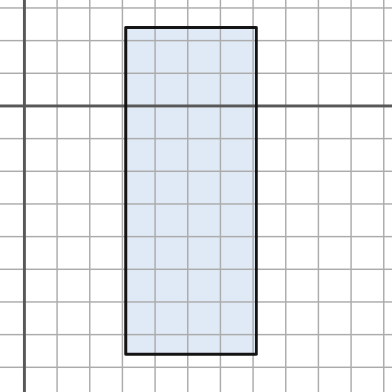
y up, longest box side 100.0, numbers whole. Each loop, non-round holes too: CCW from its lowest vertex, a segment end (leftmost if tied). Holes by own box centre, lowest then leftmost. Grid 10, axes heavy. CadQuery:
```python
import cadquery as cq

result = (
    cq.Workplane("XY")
    .moveTo(31.0, -76.0)
    .lineTo(71.0, -76.0)
    .lineTo(71.0, 24.0)
    .lineTo(31.0, 24.0)
    .close()
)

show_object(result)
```